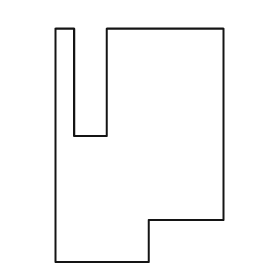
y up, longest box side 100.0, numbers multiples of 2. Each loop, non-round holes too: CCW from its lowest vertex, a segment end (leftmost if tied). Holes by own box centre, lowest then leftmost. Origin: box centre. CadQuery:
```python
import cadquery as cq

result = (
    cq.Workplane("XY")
    .moveTo(-36.0, -50.0)
    .lineTo(4.0, -50.0)
    .lineTo(4.0, -32.0)
    .lineTo(36.0, -32.0)
    .lineTo(36.0, 50.0)
    .lineTo(-14.0, 50.0)
    .lineTo(-14.0, 4.0)
    .lineTo(-28.0, 4.0)
    .lineTo(-28.0, 50.0)
    .lineTo(-36.0, 50.0)
    .close()
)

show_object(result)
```